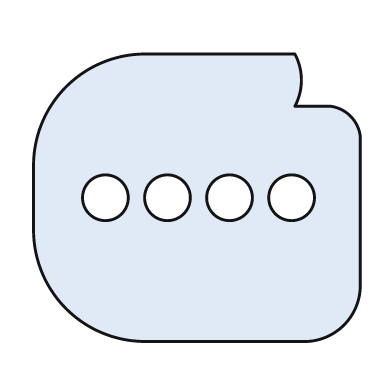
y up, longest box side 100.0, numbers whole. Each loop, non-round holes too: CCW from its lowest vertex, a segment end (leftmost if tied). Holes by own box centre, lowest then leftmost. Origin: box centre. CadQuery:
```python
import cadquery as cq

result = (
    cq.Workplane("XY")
    .moveTo(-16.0, -44.0)
    .lineTo(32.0, -44.0)
    .threePointArc((45.0, -39.0), (50.0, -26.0))
    .lineTo(50.0, 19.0)
    .threePointArc((47.0, 25.0), (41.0, 28.0))
    .lineTo(30.0, 28.0)
    .threePointArc((32.0, 36.0), (30.0, 44.0))
    .lineTo(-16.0, 44.0)
    .threePointArc((-40.0, 34.0), (-50.0, 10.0))
    .lineTo(-50.0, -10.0)
    .threePointArc((-40.0, -34.0), (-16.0, -44.0))
    .close()
    .moveTo(-28.0, 0.0)
    .circle(7.0)
    .moveTo(-9.0, 0.0)
    .circle(7.0)
    .moveTo(10.0, 0.0)
    .circle(7.0)
    .moveTo(29.0, 0.0)
    .circle(7.0)
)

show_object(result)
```